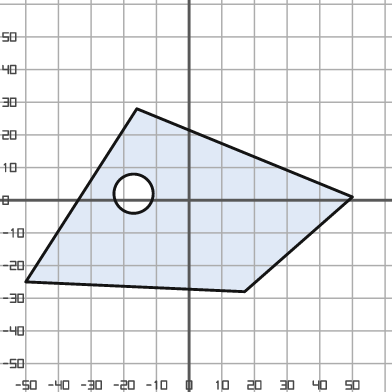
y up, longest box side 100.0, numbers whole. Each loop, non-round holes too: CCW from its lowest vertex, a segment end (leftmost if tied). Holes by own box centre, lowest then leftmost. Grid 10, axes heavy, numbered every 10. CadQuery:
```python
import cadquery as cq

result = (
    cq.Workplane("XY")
    .moveTo(17.0, -28.0)
    .lineTo(50.0, 1.0)
    .lineTo(-16.0, 28.0)
    .lineTo(-50.0, -25.0)
    .close()
    .moveTo(-17.0, 2.0)
    .circle(6.0)
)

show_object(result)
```